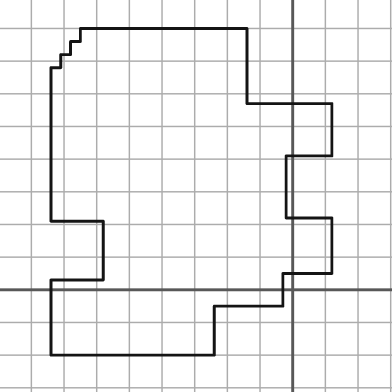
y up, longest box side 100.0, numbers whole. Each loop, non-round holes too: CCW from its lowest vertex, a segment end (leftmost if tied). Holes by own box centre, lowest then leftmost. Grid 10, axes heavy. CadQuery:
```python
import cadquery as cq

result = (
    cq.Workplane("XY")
    .moveTo(-74.0, -20.0)
    .lineTo(-24.0, -20.0)
    .lineTo(-24.0, -5.0)
    .lineTo(-3.0, -5.0)
    .lineTo(-3.0, 5.0)
    .lineTo(12.0, 5.0)
    .lineTo(12.0, 22.0)
    .lineTo(-2.0, 22.0)
    .lineTo(-2.0, 41.0)
    .lineTo(12.0, 41.0)
    .lineTo(12.0, 57.0)
    .lineTo(-14.0, 57.0)
    .lineTo(-14.0, 80.0)
    .lineTo(-65.0, 80.0)
    .lineTo(-65.0, 76.0)
    .lineTo(-68.0, 76.0)
    .lineTo(-68.0, 72.0)
    .lineTo(-71.0, 72.0)
    .lineTo(-71.0, 68.0)
    .lineTo(-74.0, 68.0)
    .lineTo(-74.0, 21.0)
    .lineTo(-58.0, 21.0)
    .lineTo(-58.0, 3.0)
    .lineTo(-74.0, 3.0)
    .close()
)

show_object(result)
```